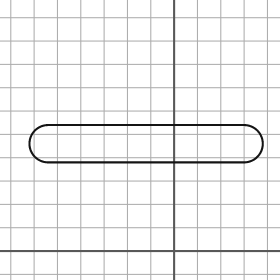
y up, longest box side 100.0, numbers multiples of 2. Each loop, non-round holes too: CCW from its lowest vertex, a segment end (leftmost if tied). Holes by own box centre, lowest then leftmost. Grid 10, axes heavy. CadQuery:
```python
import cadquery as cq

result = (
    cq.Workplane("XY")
    .moveTo(-54.0, 38.0)
    .lineTo(30.0, 38.0)
    .threePointArc((38.0, 46.0), (30.0, 54.0))
    .lineTo(-54.0, 54.0)
    .threePointArc((-62.0, 46.0), (-54.0, 38.0))
    .close()
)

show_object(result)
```